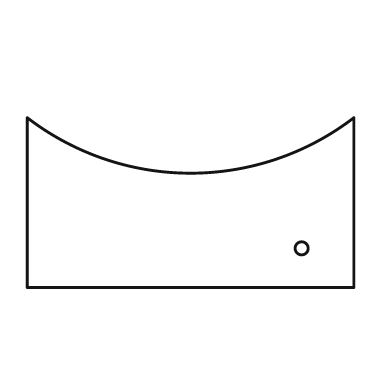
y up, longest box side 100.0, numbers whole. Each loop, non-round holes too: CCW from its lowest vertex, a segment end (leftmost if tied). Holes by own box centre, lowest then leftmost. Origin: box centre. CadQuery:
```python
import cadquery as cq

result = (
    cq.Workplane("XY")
    .moveTo(-50.0, -26.0)
    .lineTo(50.0, -26.0)
    .lineTo(50.0, 26.0)
    .threePointArc((0.0, 9.0), (-50.0, 26.0))
    .close()
    .moveTo(34.0, -14.0)
    .circle(2.0)
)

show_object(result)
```